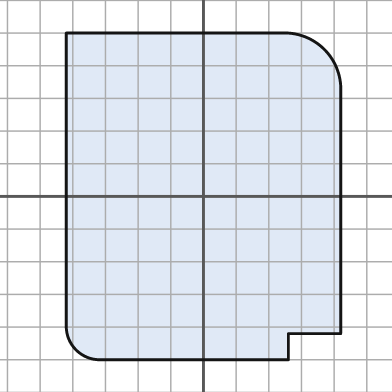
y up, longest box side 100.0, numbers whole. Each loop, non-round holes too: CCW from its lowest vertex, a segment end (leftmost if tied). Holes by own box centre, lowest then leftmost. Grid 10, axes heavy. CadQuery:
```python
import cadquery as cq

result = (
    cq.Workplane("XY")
    .moveTo(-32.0, -50.0)
    .lineTo(26.0, -50.0)
    .lineTo(26.0, -42.0)
    .lineTo(42.0, -42.0)
    .lineTo(42.0, 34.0)
    .threePointArc((37.0, 45.0), (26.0, 50.0))
    .lineTo(-42.0, 50.0)
    .lineTo(-42.0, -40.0)
    .threePointArc((-39.0, -47.0), (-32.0, -50.0))
    .close()
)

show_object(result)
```